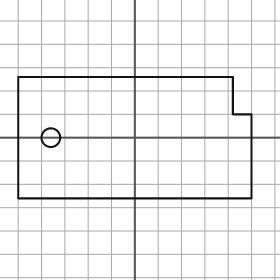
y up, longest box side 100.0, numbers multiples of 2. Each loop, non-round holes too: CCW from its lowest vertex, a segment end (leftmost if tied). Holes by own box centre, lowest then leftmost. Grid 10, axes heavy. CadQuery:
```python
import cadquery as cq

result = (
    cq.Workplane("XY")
    .moveTo(-50.0, -26.0)
    .lineTo(50.0, -26.0)
    .lineTo(50.0, 10.0)
    .lineTo(42.0, 10.0)
    .lineTo(42.0, 26.0)
    .lineTo(-50.0, 26.0)
    .close()
    .moveTo(-36.0, 0.0)
    .circle(4.0)
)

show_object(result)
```